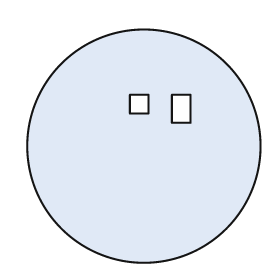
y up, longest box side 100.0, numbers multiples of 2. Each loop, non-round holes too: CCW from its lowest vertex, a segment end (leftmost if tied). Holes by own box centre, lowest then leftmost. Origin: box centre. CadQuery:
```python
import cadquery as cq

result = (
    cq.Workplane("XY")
    .moveTo(0.0, 0.0)
    .circle(50.0)
    .moveTo(12.0, 10.0)
    .lineTo(20.0, 10.0)
    .lineTo(20.0, 22.0)
    .lineTo(12.0, 22.0)
    .close()
    .moveTo(-6.0, 14.0)
    .lineTo(2.0, 14.0)
    .lineTo(2.0, 22.0)
    .lineTo(-6.0, 22.0)
    .close()
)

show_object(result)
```